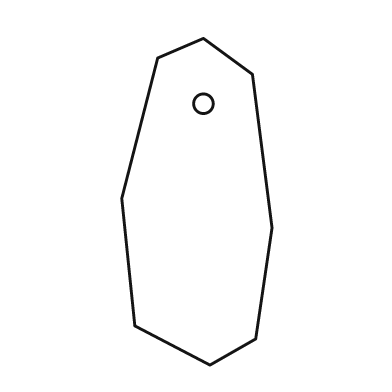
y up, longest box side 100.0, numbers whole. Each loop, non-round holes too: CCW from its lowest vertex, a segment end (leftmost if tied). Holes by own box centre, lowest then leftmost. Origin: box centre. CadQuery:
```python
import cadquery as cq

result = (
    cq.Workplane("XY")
    .moveTo(4.0, -50.0)
    .lineTo(18.0, -42.0)
    .lineTo(23.0, -8.0)
    .lineTo(17.0, 39.0)
    .lineTo(2.0, 50.0)
    .lineTo(-12.0, 44.0)
    .lineTo(-23.0, 1.0)
    .lineTo(-19.0, -38.0)
    .close()
    .moveTo(2.0, 30.0)
    .circle(3.0)
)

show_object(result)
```